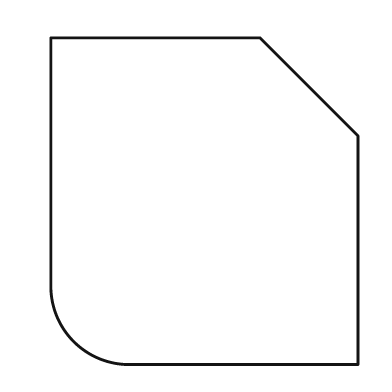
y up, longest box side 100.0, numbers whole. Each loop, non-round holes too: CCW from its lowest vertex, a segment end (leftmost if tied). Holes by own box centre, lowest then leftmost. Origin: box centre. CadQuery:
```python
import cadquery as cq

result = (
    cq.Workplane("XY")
    .moveTo(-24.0, -50.0)
    .lineTo(47.0, -50.0)
    .lineTo(47.0, 20.0)
    .lineTo(17.0, 50.0)
    .lineTo(-47.0, 50.0)
    .lineTo(-47.0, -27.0)
    .threePointArc((-40.0, -43.0), (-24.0, -50.0))
    .close()
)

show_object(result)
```